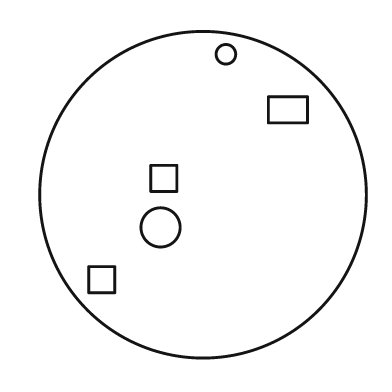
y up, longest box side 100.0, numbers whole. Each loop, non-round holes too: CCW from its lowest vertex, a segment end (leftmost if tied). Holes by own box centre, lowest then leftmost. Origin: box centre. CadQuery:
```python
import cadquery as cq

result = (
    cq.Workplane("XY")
    .moveTo(0.0, 0.0)
    .circle(50.0)
    .moveTo(-35.0, -30.0)
    .lineTo(-27.0, -30.0)
    .lineTo(-27.0, -22.0)
    .lineTo(-35.0, -22.0)
    .close()
    .moveTo(-13.0, -10.0)
    .circle(6.0)
    .moveTo(-16.0, 1.0)
    .lineTo(-8.0, 1.0)
    .lineTo(-8.0, 9.0)
    .lineTo(-16.0, 9.0)
    .close()
    .moveTo(20.0, 22.0)
    .lineTo(32.0, 22.0)
    .lineTo(32.0, 30.0)
    .lineTo(20.0, 30.0)
    .close()
    .moveTo(7.0, 43.0)
    .circle(3.0)
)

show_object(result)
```